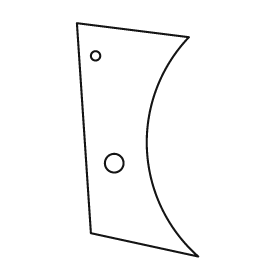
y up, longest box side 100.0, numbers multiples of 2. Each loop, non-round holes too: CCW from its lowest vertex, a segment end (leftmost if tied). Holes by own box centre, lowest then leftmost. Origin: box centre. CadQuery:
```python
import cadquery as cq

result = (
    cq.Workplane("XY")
    .moveTo(26.0, -50.0)
    .threePointArc((4.0, -4.0), (22.0, 44.0))
    .lineTo(-26.0, 50.0)
    .lineTo(-20.0, -40.0)
    .close()
    .moveTo(-10.0, -10.0)
    .circle(4.0)
    .moveTo(-18.0, 36.0)
    .circle(2.0)
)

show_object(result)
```